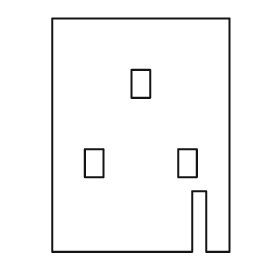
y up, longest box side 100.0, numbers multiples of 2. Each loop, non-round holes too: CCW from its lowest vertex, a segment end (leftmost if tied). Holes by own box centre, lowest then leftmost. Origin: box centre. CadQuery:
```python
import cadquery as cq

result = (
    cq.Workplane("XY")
    .moveTo(-38.0, -50.0)
    .lineTo(22.0, -50.0)
    .lineTo(22.0, -24.0)
    .lineTo(28.0, -24.0)
    .lineTo(28.0, -50.0)
    .lineTo(38.0, -50.0)
    .lineTo(38.0, 50.0)
    .lineTo(-38.0, 50.0)
    .close()
    .moveTo(-24.0, -18.0)
    .lineTo(-16.0, -18.0)
    .lineTo(-16.0, -6.0)
    .lineTo(-24.0, -6.0)
    .close()
    .moveTo(16.0, -18.0)
    .lineTo(24.0, -18.0)
    .lineTo(24.0, -6.0)
    .lineTo(16.0, -6.0)
    .close()
    .moveTo(-4.0, 16.0)
    .lineTo(4.0, 16.0)
    .lineTo(4.0, 28.0)
    .lineTo(-4.0, 28.0)
    .close()
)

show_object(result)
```